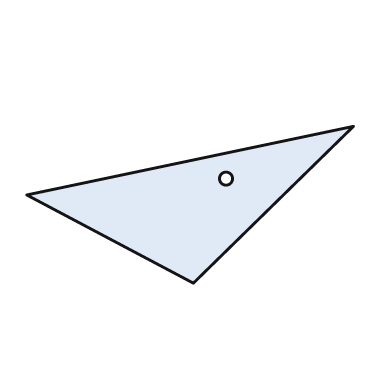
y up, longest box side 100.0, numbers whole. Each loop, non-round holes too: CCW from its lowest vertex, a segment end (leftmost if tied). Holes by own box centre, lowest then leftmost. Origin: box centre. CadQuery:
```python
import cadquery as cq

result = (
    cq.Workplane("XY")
    .moveTo(1.0, -24.0)
    .lineTo(50.0, 24.0)
    .lineTo(-50.0, 3.0)
    .close()
    .moveTo(11.0, 8.0)
    .circle(2.0)
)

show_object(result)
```